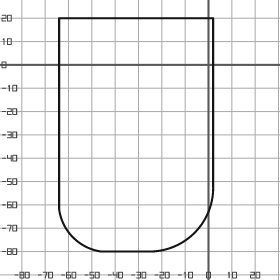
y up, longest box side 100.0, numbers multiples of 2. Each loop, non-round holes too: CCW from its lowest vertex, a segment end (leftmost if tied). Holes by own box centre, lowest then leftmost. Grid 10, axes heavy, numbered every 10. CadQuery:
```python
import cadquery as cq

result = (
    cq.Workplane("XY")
    .moveTo(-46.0, -80.0)
    .lineTo(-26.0, -80.0)
    .threePointArc((-6.0, -72.0), (2.0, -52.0))
    .lineTo(2.0, 20.0)
    .lineTo(-64.0, 20.0)
    .lineTo(-64.0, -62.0)
    .threePointArc((-58.0, -74.0), (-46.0, -80.0))
    .close()
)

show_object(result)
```